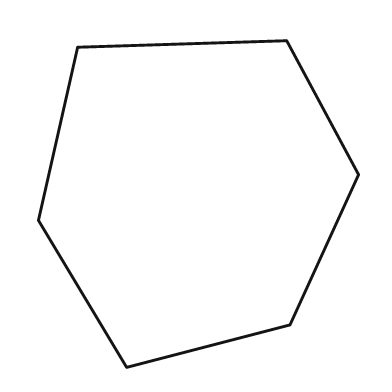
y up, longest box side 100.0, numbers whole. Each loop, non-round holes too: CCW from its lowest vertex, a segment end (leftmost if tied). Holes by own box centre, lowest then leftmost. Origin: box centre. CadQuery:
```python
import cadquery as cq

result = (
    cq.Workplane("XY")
    .moveTo(-22.0, -50.0)
    .lineTo(28.0, -37.0)
    .lineTo(49.0, 9.0)
    .lineTo(27.0, 50.0)
    .lineTo(-37.0, 48.0)
    .lineTo(-49.0, -5.0)
    .close()
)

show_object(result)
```